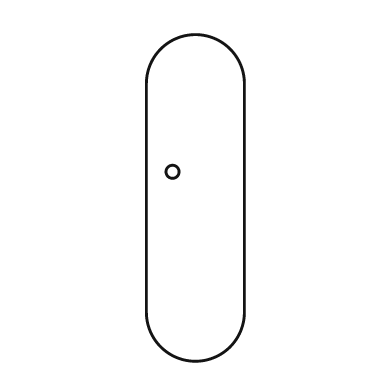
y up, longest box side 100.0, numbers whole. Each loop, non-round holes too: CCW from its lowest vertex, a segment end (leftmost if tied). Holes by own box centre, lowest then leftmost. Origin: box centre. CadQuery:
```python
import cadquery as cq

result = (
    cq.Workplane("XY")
    .moveTo(-15.0, -35.0)
    .threePointArc((0.0, -50.0), (15.0, -35.0))
    .lineTo(15.0, 35.0)
    .threePointArc((0.0, 50.0), (-15.0, 35.0))
    .close()
    .moveTo(-7.0, 8.0)
    .circle(2.0)
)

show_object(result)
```